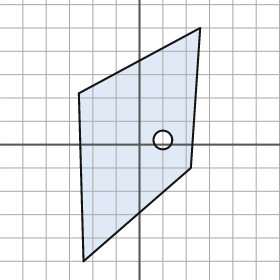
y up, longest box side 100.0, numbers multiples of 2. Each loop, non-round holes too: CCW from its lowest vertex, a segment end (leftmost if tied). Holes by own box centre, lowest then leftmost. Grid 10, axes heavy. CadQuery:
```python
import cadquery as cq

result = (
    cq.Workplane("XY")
    .moveTo(-24.0, -50.0)
    .lineTo(22.0, -10.0)
    .lineTo(26.0, 50.0)
    .lineTo(-26.0, 22.0)
    .close()
    .moveTo(10.0, 2.0)
    .circle(4.0)
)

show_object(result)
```